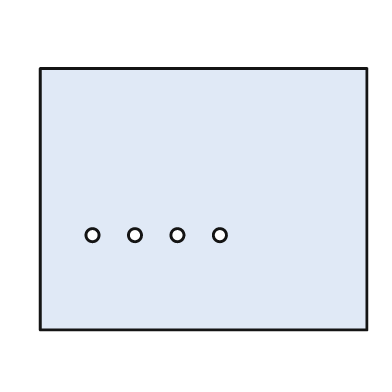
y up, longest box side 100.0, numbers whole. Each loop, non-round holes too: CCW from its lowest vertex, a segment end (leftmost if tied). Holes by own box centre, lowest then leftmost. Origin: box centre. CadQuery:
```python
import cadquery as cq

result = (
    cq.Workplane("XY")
    .moveTo(-50.0, -40.0)
    .lineTo(50.0, -40.0)
    .lineTo(50.0, 40.0)
    .lineTo(-50.0, 40.0)
    .close()
    .moveTo(-34.0, -11.0)
    .circle(2.0)
    .moveTo(-21.0, -11.0)
    .circle(2.0)
    .moveTo(-8.0, -11.0)
    .circle(2.0)
    .moveTo(5.0, -11.0)
    .circle(2.0)
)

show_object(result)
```